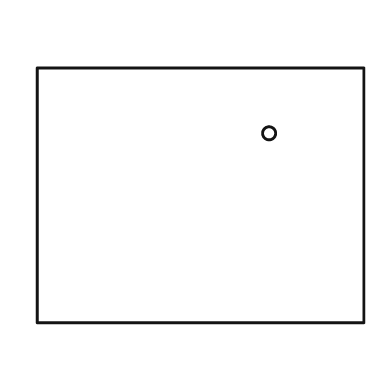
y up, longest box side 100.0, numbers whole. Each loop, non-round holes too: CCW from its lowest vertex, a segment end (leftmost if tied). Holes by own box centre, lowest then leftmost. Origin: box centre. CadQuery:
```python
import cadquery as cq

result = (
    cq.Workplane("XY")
    .moveTo(-50.0, -39.0)
    .lineTo(50.0, -39.0)
    .lineTo(50.0, 39.0)
    .lineTo(-50.0, 39.0)
    .close()
    .moveTo(21.0, 19.0)
    .circle(2.0)
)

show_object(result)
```